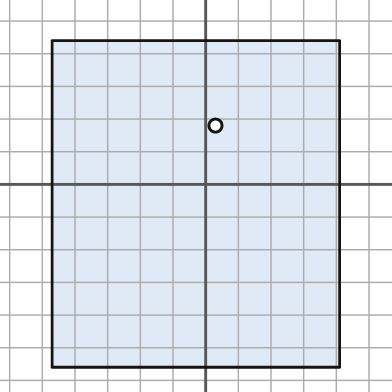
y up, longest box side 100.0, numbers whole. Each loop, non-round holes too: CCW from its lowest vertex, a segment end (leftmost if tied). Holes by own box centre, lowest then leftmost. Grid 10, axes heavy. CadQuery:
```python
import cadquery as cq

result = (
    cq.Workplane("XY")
    .moveTo(-47.0, -56.0)
    .lineTo(41.0, -56.0)
    .lineTo(41.0, 44.0)
    .lineTo(-47.0, 44.0)
    .close()
    .moveTo(3.0, 18.0)
    .circle(2.0)
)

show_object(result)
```